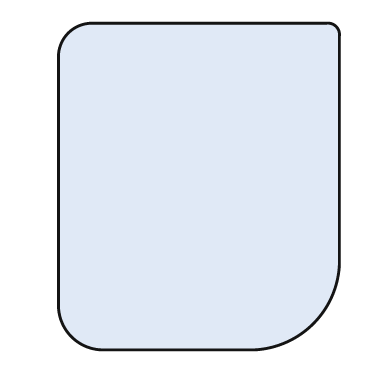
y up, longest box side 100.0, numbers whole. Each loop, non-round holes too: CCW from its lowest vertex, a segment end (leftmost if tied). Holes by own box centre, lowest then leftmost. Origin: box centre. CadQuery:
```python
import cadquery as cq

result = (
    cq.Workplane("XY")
    .moveTo(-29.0, -50.0)
    .lineTo(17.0, -50.0)
    .threePointArc((35.0, -42.0), (43.0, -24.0))
    .lineTo(43.0, 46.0)
    .threePointArc((42.0, 49.0), (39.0, 50.0))
    .lineTo(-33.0, 50.0)
    .threePointArc((-40.0, 47.0), (-43.0, 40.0))
    .lineTo(-43.0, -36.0)
    .threePointArc((-39.0, -46.0), (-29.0, -50.0))
    .close()
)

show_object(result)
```